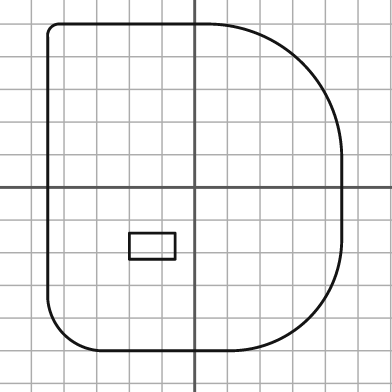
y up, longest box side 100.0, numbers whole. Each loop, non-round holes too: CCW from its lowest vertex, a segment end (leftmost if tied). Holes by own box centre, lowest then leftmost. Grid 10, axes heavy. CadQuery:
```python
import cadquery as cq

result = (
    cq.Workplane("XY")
    .moveTo(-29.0, -50.0)
    .lineTo(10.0, -50.0)
    .threePointArc((35.0, -40.0), (45.0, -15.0))
    .lineTo(45.0, 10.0)
    .threePointArc((33.0, 38.0), (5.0, 50.0))
    .lineTo(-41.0, 50.0)
    .threePointArc((-44.0, 49.0), (-45.0, 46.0))
    .lineTo(-45.0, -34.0)
    .threePointArc((-40.0, -45.0), (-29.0, -50.0))
    .close()
    .moveTo(-20.0, -22.0)
    .lineTo(-6.0, -22.0)
    .lineTo(-6.0, -14.0)
    .lineTo(-20.0, -14.0)
    .close()
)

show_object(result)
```